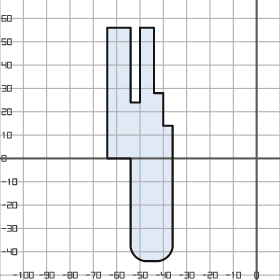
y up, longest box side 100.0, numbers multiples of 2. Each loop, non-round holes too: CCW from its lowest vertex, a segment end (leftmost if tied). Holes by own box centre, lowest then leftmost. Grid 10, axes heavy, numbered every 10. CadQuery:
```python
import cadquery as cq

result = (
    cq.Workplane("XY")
    .moveTo(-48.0, -44.0)
    .lineTo(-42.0, -44.0)
    .threePointArc((-38.0, -42.0), (-36.0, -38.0))
    .lineTo(-36.0, 14.0)
    .lineTo(-40.0, 14.0)
    .lineTo(-40.0, 28.0)
    .lineTo(-44.0, 28.0)
    .lineTo(-44.0, 56.0)
    .lineTo(-50.0, 56.0)
    .lineTo(-50.0, 24.0)
    .lineTo(-54.0, 24.0)
    .lineTo(-54.0, 56.0)
    .lineTo(-64.0, 56.0)
    .lineTo(-64.0, 0.0)
    .lineTo(-54.0, 0.0)
    .lineTo(-54.0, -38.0)
    .threePointArc((-52.0, -42.0), (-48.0, -44.0))
    .close()
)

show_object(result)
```